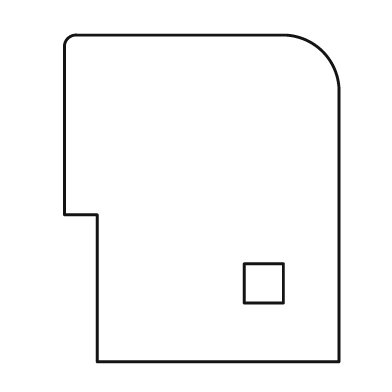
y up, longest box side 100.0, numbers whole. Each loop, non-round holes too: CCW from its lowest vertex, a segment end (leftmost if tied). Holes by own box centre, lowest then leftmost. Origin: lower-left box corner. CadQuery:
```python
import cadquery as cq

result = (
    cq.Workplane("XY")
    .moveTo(10.0, 0.0)
    .lineTo(84.0, 0.0)
    .lineTo(84.0, 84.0)
    .threePointArc((79.0, 95.0), (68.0, 100.0))
    .lineTo(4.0, 100.0)
    .threePointArc((1.0, 99.0), (0.0, 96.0))
    .lineTo(0.0, 45.0)
    .lineTo(10.0, 45.0)
    .close()
    .moveTo(55.0, 18.0)
    .lineTo(67.0, 18.0)
    .lineTo(67.0, 30.0)
    .lineTo(55.0, 30.0)
    .close()
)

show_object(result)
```